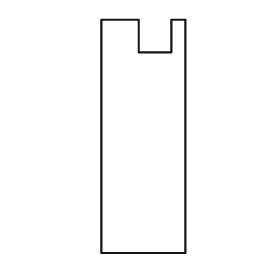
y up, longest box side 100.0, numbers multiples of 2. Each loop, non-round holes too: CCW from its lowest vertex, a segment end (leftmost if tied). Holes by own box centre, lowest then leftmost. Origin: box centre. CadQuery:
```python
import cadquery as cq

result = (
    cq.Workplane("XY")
    .moveTo(-18.0, -50.0)
    .lineTo(18.0, -50.0)
    .lineTo(18.0, 50.0)
    .lineTo(12.0, 50.0)
    .lineTo(12.0, 36.0)
    .lineTo(-2.0, 36.0)
    .lineTo(-2.0, 50.0)
    .lineTo(-18.0, 50.0)
    .close()
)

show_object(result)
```